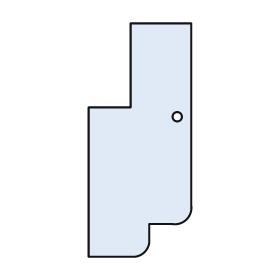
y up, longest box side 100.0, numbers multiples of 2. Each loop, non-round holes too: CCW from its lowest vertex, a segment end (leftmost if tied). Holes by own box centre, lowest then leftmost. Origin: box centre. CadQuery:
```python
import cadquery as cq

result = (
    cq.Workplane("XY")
    .moveTo(-22.0, -50.0)
    .lineTo(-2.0, -50.0)
    .threePointArc((2.0, -48.0), (4.0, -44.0))
    .lineTo(4.0, -36.0)
    .lineTo(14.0, -36.0)
    .threePointArc((20.0, -34.0), (22.0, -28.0))
    .lineTo(22.0, 50.0)
    .lineTo(-4.0, 50.0)
    .lineTo(-4.0, 14.0)
    .lineTo(-22.0, 14.0)
    .close()
    .moveTo(16.0, 10.0)
    .circle(2.0)
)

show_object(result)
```